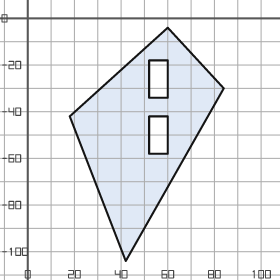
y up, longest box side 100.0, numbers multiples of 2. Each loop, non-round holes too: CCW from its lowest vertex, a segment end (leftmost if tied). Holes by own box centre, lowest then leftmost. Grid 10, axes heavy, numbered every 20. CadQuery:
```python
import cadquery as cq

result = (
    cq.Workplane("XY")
    .moveTo(42.0, -104.0)
    .lineTo(84.0, -30.0)
    .lineTo(60.0, -4.0)
    .lineTo(18.0, -42.0)
    .close()
    .moveTo(52.0, -58.0)
    .lineTo(60.0, -58.0)
    .lineTo(60.0, -42.0)
    .lineTo(52.0, -42.0)
    .close()
    .moveTo(52.0, -34.0)
    .lineTo(60.0, -34.0)
    .lineTo(60.0, -18.0)
    .lineTo(52.0, -18.0)
    .close()
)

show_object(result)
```